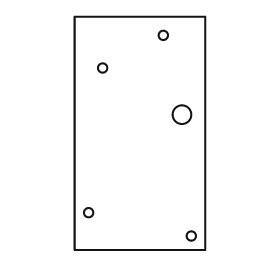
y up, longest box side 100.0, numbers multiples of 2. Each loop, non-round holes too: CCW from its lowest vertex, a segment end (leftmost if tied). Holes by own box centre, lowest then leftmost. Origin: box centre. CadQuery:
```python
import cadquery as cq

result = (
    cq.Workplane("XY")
    .moveTo(-28.0, -50.0)
    .lineTo(28.0, -50.0)
    .lineTo(28.0, 50.0)
    .lineTo(-28.0, 50.0)
    .close()
    .moveTo(22.0, -44.0)
    .circle(2.0)
    .moveTo(-22.0, -34.0)
    .circle(2.0)
    .moveTo(18.0, 8.0)
    .circle(4.0)
    .moveTo(-16.0, 28.0)
    .circle(2.0)
    .moveTo(10.0, 42.0)
    .circle(2.0)
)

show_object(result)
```